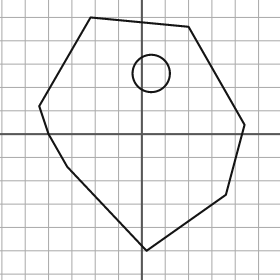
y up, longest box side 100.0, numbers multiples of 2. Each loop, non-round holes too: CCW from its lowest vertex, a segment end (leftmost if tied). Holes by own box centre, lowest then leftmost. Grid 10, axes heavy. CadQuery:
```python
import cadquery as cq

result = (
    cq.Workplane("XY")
    .moveTo(2.0, -50.0)
    .lineTo(36.0, -26.0)
    .lineTo(44.0, 4.0)
    .lineTo(20.0, 46.0)
    .lineTo(-22.0, 50.0)
    .lineTo(-44.0, 12.0)
    .lineTo(-40.0, 0.0)
    .lineTo(-32.0, -14.0)
    .close()
    .moveTo(4.0, 26.0)
    .circle(8.0)
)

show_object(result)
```